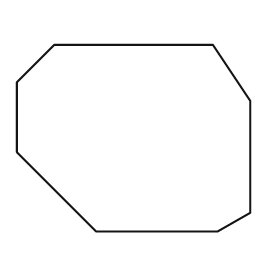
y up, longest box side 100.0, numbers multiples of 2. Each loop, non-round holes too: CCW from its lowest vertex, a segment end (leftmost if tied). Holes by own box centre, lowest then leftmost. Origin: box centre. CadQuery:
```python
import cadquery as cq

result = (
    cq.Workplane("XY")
    .moveTo(-16.0, -40.0)
    .lineTo(36.0, -40.0)
    .lineTo(50.0, -32.0)
    .lineTo(50.0, 16.0)
    .lineTo(34.0, 40.0)
    .lineTo(-34.0, 40.0)
    .lineTo(-50.0, 24.0)
    .lineTo(-50.0, -6.0)
    .close()
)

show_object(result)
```